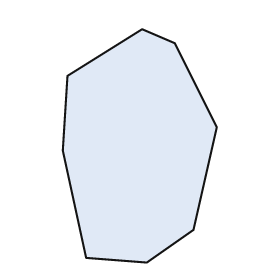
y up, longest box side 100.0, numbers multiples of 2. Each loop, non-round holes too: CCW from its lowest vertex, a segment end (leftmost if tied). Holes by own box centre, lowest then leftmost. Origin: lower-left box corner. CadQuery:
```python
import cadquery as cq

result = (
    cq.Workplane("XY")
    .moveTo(36.0, 0.0)
    .lineTo(56.0, 14.0)
    .lineTo(66.0, 58.0)
    .lineTo(48.0, 94.0)
    .lineTo(34.0, 100.0)
    .lineTo(2.0, 80.0)
    .lineTo(0.0, 48.0)
    .lineTo(10.0, 2.0)
    .close()
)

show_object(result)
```